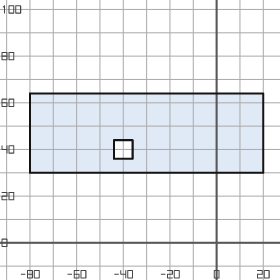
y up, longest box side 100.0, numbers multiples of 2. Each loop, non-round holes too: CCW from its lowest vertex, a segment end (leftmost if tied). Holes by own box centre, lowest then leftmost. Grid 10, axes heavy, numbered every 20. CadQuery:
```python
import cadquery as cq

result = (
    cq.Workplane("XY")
    .moveTo(-80.0, 30.0)
    .lineTo(20.0, 30.0)
    .lineTo(20.0, 64.0)
    .lineTo(-80.0, 64.0)
    .close()
    .moveTo(-44.0, 36.0)
    .lineTo(-36.0, 36.0)
    .lineTo(-36.0, 44.0)
    .lineTo(-44.0, 44.0)
    .close()
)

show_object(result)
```